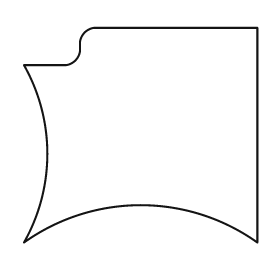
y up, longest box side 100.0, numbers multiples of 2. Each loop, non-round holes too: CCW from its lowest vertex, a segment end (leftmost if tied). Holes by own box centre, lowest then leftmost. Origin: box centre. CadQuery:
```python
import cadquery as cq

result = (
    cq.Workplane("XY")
    .moveTo(-50.0, -46.0)
    .threePointArc((0.0, -30.0), (50.0, -46.0))
    .lineTo(50.0, 46.0)
    .lineTo(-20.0, 46.0)
    .threePointArc((-24.0, 44.0), (-26.0, 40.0))
    .lineTo(-26.0, 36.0)
    .threePointArc((-28.0, 32.0), (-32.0, 30.0))
    .lineTo(-50.0, 30.0)
    .threePointArc((-40.0, -8.0), (-50.0, -46.0))
    .close()
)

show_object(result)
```